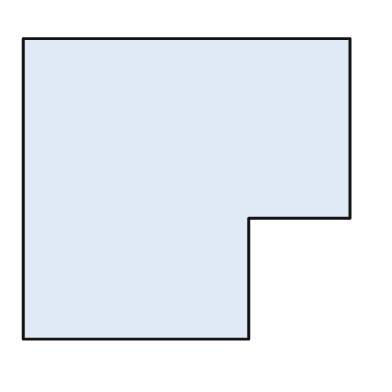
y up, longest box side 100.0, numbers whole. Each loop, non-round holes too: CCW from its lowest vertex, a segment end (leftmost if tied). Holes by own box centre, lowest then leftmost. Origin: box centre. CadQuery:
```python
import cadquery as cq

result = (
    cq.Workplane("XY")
    .moveTo(-50.0, -46.0)
    .lineTo(19.0, -46.0)
    .lineTo(19.0, -9.0)
    .lineTo(50.0, -9.0)
    .lineTo(50.0, 46.0)
    .lineTo(-50.0, 46.0)
    .close()
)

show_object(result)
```